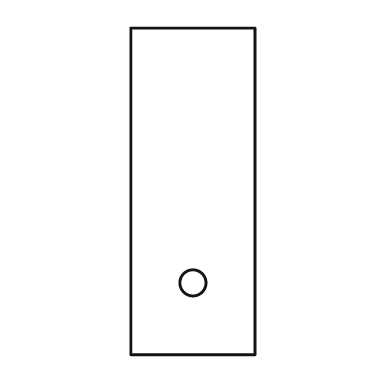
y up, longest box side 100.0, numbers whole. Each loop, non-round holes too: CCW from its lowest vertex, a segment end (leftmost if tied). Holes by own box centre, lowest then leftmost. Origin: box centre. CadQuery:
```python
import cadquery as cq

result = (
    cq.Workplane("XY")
    .moveTo(-19.0, -50.0)
    .lineTo(19.0, -50.0)
    .lineTo(19.0, 50.0)
    .lineTo(-19.0, 50.0)
    .close()
    .moveTo(0.0, -28.0)
    .circle(4.0)
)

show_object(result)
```